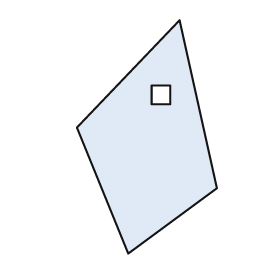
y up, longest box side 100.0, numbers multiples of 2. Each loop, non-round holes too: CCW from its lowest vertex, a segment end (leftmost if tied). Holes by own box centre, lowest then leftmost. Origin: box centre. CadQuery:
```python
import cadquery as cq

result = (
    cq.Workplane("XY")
    .moveTo(-8.0, -50.0)
    .lineTo(30.0, -22.0)
    .lineTo(14.0, 50.0)
    .lineTo(-30.0, 4.0)
    .close()
    .moveTo(2.0, 14.0)
    .lineTo(10.0, 14.0)
    .lineTo(10.0, 22.0)
    .lineTo(2.0, 22.0)
    .close()
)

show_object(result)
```